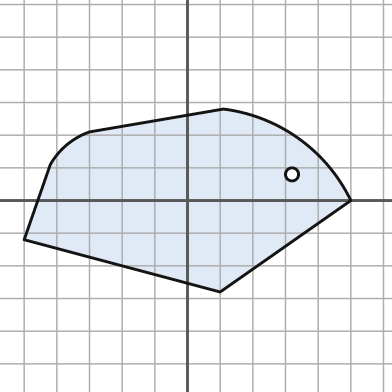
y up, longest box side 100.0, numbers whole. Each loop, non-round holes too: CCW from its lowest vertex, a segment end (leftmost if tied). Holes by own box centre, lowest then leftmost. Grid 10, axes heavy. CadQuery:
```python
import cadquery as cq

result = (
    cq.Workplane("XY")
    .moveTo(10.0, -28.0)
    .lineTo(50.0, 0.0)
    .threePointArc((34.0, 19.0), (11.0, 28.0))
    .lineTo(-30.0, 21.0)
    .threePointArc((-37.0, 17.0), (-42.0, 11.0))
    .lineTo(-50.0, -12.0)
    .close()
    .moveTo(32.0, 8.0)
    .circle(2.0)
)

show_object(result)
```